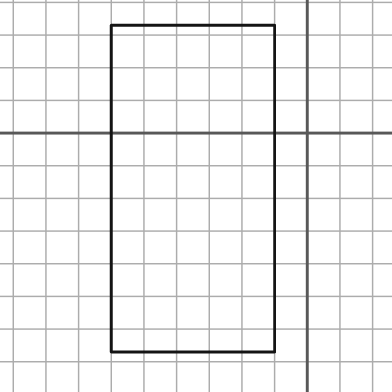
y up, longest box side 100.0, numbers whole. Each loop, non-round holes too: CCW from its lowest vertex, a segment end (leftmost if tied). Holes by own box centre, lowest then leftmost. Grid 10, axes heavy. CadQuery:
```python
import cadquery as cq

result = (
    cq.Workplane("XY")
    .moveTo(-60.0, -67.0)
    .lineTo(-10.0, -67.0)
    .lineTo(-10.0, 33.0)
    .lineTo(-60.0, 33.0)
    .close()
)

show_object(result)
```